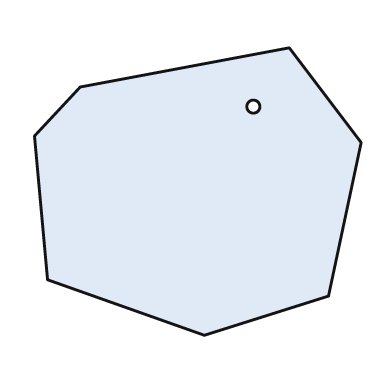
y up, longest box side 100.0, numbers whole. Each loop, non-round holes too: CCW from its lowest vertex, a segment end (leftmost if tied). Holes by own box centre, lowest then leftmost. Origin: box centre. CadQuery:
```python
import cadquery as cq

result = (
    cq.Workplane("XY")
    .moveTo(2.0, -44.0)
    .lineTo(40.0, -32.0)
    .lineTo(50.0, 15.0)
    .lineTo(28.0, 44.0)
    .lineTo(-36.0, 32.0)
    .lineTo(-50.0, 17.0)
    .lineTo(-46.0, -27.0)
    .close()
    .moveTo(17.0, 26.0)
    .circle(2.0)
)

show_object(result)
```